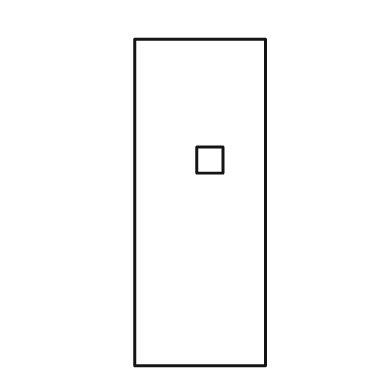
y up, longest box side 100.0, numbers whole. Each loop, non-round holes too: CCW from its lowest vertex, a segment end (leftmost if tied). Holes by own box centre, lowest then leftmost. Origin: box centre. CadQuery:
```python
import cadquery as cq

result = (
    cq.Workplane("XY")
    .moveTo(-20.0, -50.0)
    .lineTo(20.0, -50.0)
    .lineTo(20.0, 50.0)
    .lineTo(-20.0, 50.0)
    .close()
    .moveTo(-1.0, 9.0)
    .lineTo(7.0, 9.0)
    .lineTo(7.0, 17.0)
    .lineTo(-1.0, 17.0)
    .close()
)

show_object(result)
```